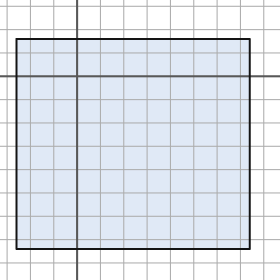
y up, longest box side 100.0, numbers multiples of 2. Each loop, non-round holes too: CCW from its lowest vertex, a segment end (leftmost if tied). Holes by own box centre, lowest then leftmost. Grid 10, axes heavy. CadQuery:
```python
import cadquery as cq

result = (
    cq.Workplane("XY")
    .moveTo(-26.0, -74.0)
    .lineTo(74.0, -74.0)
    .lineTo(74.0, 16.0)
    .lineTo(-26.0, 16.0)
    .close()
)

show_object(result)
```